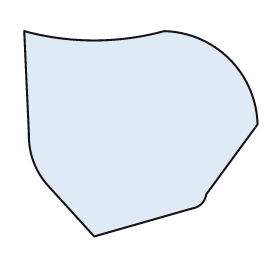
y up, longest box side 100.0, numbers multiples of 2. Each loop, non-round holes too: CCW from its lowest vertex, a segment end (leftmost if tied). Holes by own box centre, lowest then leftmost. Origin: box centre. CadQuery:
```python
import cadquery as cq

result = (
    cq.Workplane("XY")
    .moveTo(-20.0, -44.0)
    .lineTo(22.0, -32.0)
    .threePointArc((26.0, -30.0), (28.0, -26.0))
    .lineTo(50.0, 4.0)
    .threePointArc((38.0, 32.0), (10.0, 44.0))
    .threePointArc((-20.0, 40.0), (-50.0, 44.0))
    .lineTo(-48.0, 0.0)
    .threePointArc((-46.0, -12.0), (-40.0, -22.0))
    .close()
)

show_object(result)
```